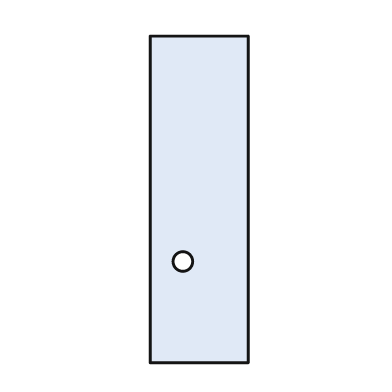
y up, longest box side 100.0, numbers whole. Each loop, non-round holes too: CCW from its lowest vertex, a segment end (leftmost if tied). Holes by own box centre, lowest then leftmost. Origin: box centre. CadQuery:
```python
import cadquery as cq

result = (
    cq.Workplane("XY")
    .moveTo(-15.0, -50.0)
    .lineTo(15.0, -50.0)
    .lineTo(15.0, 50.0)
    .lineTo(-15.0, 50.0)
    .close()
    .moveTo(-5.0, -19.0)
    .circle(3.0)
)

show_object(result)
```